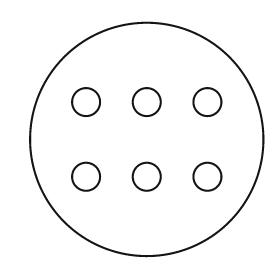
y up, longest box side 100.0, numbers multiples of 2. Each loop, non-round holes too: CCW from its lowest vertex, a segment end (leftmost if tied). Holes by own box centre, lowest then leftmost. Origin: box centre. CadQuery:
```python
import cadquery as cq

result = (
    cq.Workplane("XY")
    .moveTo(0.0, 0.0)
    .circle(50.0)
    .moveTo(-26.0, -16.0)
    .circle(6.0)
    .moveTo(0.0, -16.0)
    .circle(6.0)
    .moveTo(26.0, -16.0)
    .circle(6.0)
    .moveTo(-26.0, 16.0)
    .circle(6.0)
    .moveTo(0.0, 16.0)
    .circle(6.0)
    .moveTo(26.0, 16.0)
    .circle(6.0)
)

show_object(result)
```